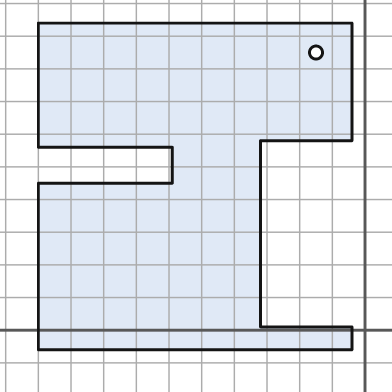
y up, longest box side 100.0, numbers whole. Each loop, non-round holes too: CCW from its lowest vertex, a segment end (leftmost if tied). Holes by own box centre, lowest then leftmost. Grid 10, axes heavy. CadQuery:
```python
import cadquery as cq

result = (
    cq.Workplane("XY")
    .moveTo(-100.0, -6.0)
    .lineTo(-4.0, -6.0)
    .lineTo(-4.0, 1.0)
    .lineTo(-32.0, 1.0)
    .lineTo(-32.0, 58.0)
    .lineTo(-4.0, 58.0)
    .lineTo(-4.0, 94.0)
    .lineTo(-100.0, 94.0)
    .lineTo(-100.0, 56.0)
    .lineTo(-59.0, 56.0)
    .lineTo(-59.0, 45.0)
    .lineTo(-100.0, 45.0)
    .close()
    .moveTo(-15.0, 85.0)
    .circle(2.0)
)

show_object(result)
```